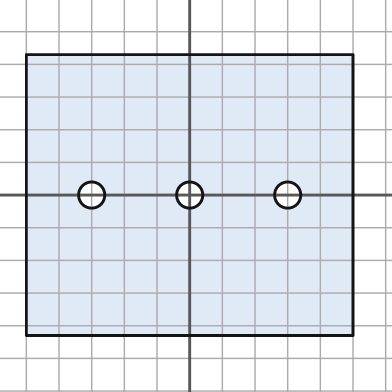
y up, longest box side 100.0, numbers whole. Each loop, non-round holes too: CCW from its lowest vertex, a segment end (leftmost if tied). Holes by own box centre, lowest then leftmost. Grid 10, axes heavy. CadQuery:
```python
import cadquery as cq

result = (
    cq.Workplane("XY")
    .moveTo(-50.0, -43.0)
    .lineTo(50.0, -43.0)
    .lineTo(50.0, 43.0)
    .lineTo(-50.0, 43.0)
    .close()
    .moveTo(-30.0, 0.0)
    .circle(4.0)
    .moveTo(0.0, 0.0)
    .circle(4.0)
    .moveTo(30.0, 0.0)
    .circle(4.0)
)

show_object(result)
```